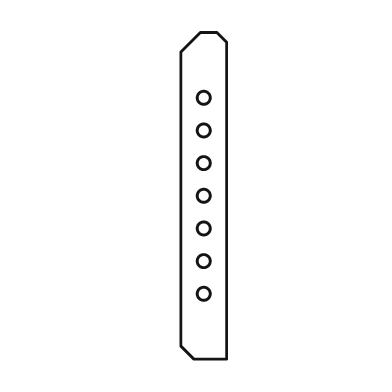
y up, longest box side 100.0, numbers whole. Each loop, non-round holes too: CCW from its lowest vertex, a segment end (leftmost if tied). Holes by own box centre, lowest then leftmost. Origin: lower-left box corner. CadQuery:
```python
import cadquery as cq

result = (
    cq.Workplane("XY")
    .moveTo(4.0, 0.0)
    .lineTo(14.0, 0.0)
    .lineTo(14.0, 97.0)
    .lineTo(11.0, 100.0)
    .lineTo(6.0, 100.0)
    .lineTo(0.0, 94.0)
    .lineTo(0.0, 4.0)
    .close()
    .moveTo(7.0, 20.0)
    .circle(2.0)
    .moveTo(7.0, 30.0)
    .circle(2.0)
    .moveTo(7.0, 40.0)
    .circle(2.0)
    .moveTo(7.0, 50.0)
    .circle(2.0)
    .moveTo(7.0, 60.0)
    .circle(2.0)
    .moveTo(7.0, 70.0)
    .circle(2.0)
    .moveTo(7.0, 80.0)
    .circle(2.0)
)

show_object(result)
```